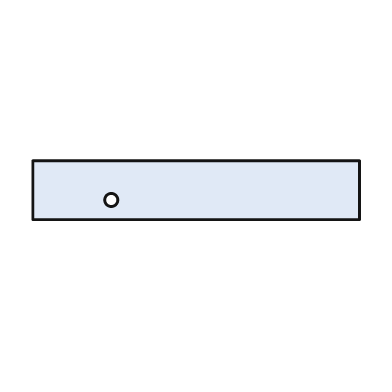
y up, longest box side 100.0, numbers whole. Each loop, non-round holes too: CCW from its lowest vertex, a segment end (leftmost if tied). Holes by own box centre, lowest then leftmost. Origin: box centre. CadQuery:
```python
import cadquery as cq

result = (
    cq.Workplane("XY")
    .moveTo(-50.0, -9.0)
    .lineTo(50.0, -9.0)
    .lineTo(50.0, 9.0)
    .lineTo(-50.0, 9.0)
    .close()
    .moveTo(-26.0, -3.0)
    .circle(2.0)
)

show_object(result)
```